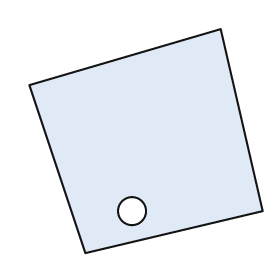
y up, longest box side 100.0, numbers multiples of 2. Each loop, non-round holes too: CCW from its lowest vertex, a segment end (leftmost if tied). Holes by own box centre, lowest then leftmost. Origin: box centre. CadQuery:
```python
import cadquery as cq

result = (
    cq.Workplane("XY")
    .moveTo(-26.0, -48.0)
    .lineTo(50.0, -30.0)
    .lineTo(32.0, 48.0)
    .lineTo(-50.0, 24.0)
    .close()
    .moveTo(-6.0, -30.0)
    .circle(6.0)
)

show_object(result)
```